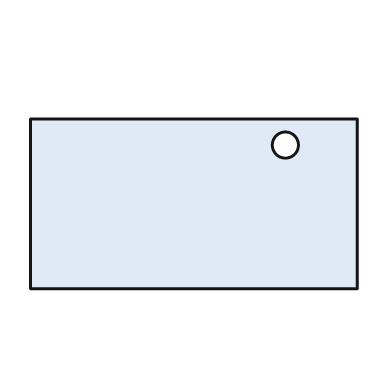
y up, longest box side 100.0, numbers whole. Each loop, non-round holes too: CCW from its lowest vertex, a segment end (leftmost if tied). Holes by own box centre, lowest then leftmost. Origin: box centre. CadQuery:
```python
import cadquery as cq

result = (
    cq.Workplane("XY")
    .moveTo(-50.0, -26.0)
    .lineTo(50.0, -26.0)
    .lineTo(50.0, 26.0)
    .lineTo(-50.0, 26.0)
    .close()
    .moveTo(28.0, 18.0)
    .circle(4.0)
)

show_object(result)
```